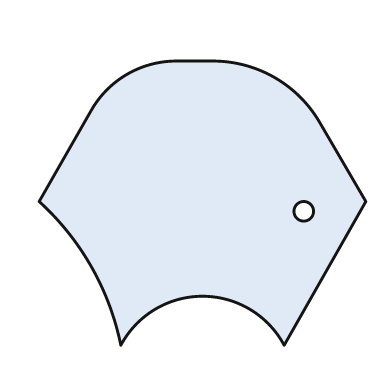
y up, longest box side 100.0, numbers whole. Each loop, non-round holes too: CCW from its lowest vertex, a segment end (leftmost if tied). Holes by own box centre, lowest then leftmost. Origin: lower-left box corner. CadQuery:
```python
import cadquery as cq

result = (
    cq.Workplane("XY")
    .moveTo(25.0, 0.0)
    .threePointArc((50.0, 15.0), (75.0, 0.0))
    .lineTo(100.0, 44.0)
    .lineTo(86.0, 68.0)
    .threePointArc((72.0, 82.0), (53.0, 87.0))
    .lineTo(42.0, 87.0)
    .threePointArc((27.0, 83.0), (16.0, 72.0))
    .lineTo(0.0, 44.0)
    .threePointArc((16.0, 24.0), (25.0, 0.0))
    .close()
    .moveTo(81.0, 41.0)
    .circle(3.0)
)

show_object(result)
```